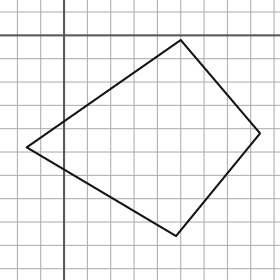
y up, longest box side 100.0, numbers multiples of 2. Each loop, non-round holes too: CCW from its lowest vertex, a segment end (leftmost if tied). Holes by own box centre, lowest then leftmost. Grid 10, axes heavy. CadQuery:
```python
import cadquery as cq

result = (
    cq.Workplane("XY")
    .moveTo(48.0, -86.0)
    .lineTo(84.0, -42.0)
    .lineTo(50.0, -2.0)
    .lineTo(-16.0, -48.0)
    .close()
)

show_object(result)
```